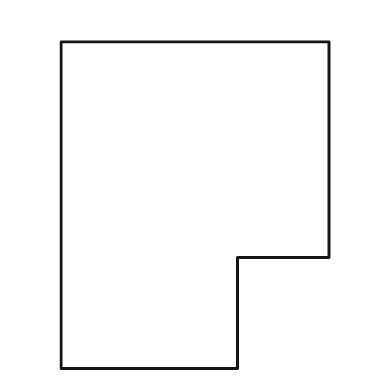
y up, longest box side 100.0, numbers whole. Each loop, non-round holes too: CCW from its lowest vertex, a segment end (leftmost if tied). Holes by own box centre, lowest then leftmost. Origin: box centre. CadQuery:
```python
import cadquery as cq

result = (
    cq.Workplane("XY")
    .moveTo(-41.0, -50.0)
    .lineTo(13.0, -50.0)
    .lineTo(13.0, -16.0)
    .lineTo(41.0, -16.0)
    .lineTo(41.0, 50.0)
    .lineTo(-41.0, 50.0)
    .close()
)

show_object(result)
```